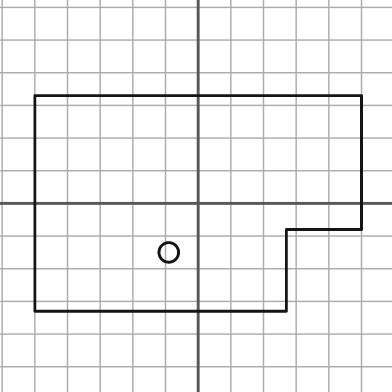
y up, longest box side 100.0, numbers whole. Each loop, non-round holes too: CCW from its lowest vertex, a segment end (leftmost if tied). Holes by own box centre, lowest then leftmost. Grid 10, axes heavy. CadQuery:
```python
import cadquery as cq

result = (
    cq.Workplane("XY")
    .moveTo(-50.0, -33.0)
    .lineTo(27.0, -33.0)
    .lineTo(27.0, -8.0)
    .lineTo(50.0, -8.0)
    .lineTo(50.0, 33.0)
    .lineTo(-50.0, 33.0)
    .close()
    .moveTo(-9.0, -15.0)
    .circle(3.0)
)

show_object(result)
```